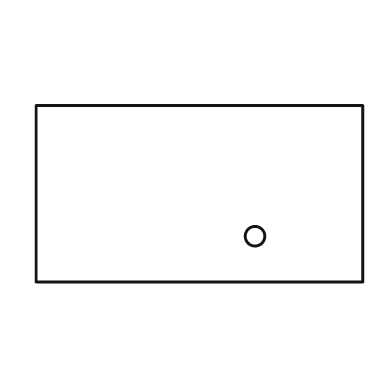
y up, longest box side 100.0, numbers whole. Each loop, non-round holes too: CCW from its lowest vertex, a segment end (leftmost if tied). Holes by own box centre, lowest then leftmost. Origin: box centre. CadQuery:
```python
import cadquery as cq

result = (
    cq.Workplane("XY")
    .moveTo(-50.0, -27.0)
    .lineTo(50.0, -27.0)
    .lineTo(50.0, 27.0)
    .lineTo(-50.0, 27.0)
    .close()
    .moveTo(17.0, -13.0)
    .circle(3.0)
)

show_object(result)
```